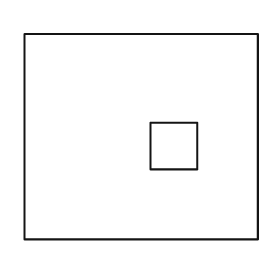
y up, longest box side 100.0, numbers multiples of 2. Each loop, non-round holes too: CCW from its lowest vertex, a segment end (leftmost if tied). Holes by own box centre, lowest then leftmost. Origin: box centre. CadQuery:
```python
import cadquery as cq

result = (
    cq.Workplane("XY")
    .moveTo(-50.0, -44.0)
    .lineTo(50.0, -44.0)
    .lineTo(50.0, 44.0)
    .lineTo(-50.0, 44.0)
    .close()
    .moveTo(4.0, -14.0)
    .lineTo(24.0, -14.0)
    .lineTo(24.0, 6.0)
    .lineTo(4.0, 6.0)
    .close()
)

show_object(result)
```